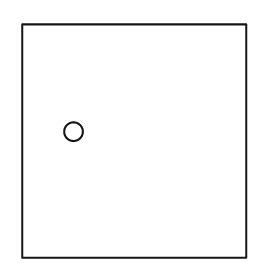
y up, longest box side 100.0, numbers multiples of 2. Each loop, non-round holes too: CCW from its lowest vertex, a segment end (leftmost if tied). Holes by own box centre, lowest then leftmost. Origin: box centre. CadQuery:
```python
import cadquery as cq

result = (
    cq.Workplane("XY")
    .moveTo(-48.0, -50.0)
    .lineTo(48.0, -50.0)
    .lineTo(48.0, 50.0)
    .lineTo(-48.0, 50.0)
    .close()
    .moveTo(-26.0, 4.0)
    .circle(4.0)
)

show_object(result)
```